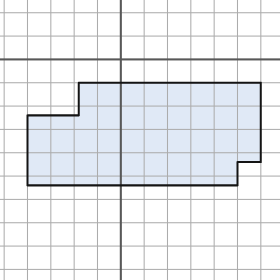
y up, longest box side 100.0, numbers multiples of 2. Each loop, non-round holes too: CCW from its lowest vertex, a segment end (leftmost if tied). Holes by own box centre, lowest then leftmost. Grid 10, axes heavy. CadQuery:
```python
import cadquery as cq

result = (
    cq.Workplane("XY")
    .moveTo(-40.0, -54.0)
    .lineTo(50.0, -54.0)
    .lineTo(50.0, -44.0)
    .lineTo(60.0, -44.0)
    .lineTo(60.0, -10.0)
    .lineTo(-18.0, -10.0)
    .lineTo(-18.0, -24.0)
    .lineTo(-40.0, -24.0)
    .close()
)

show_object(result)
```